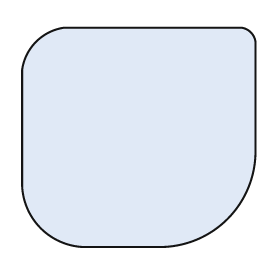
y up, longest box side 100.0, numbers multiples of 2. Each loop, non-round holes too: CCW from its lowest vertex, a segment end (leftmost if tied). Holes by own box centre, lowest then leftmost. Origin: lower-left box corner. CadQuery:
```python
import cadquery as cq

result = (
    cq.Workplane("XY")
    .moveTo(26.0, 0.0)
    .lineTo(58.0, 0.0)
    .threePointArc((88.0, 12.0), (100.0, 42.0))
    .lineTo(100.0, 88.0)
    .threePointArc((98.0, 92.0), (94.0, 94.0))
    .lineTo(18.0, 94.0)
    .threePointArc((6.0, 88.0), (0.0, 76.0))
    .lineTo(0.0, 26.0)
    .threePointArc((8.0, 8.0), (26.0, 0.0))
    .close()
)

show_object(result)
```